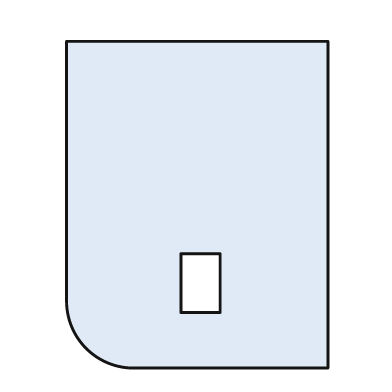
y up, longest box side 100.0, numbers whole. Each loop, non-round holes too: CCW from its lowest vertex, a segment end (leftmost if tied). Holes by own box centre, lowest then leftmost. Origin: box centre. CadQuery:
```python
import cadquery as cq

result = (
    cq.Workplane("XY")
    .moveTo(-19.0, -50.0)
    .lineTo(40.0, -50.0)
    .lineTo(40.0, 50.0)
    .lineTo(-40.0, 50.0)
    .lineTo(-40.0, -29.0)
    .threePointArc((-34.0, -44.0), (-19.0, -50.0))
    .close()
    .moveTo(-5.0, -33.0)
    .lineTo(7.0, -33.0)
    .lineTo(7.0, -15.0)
    .lineTo(-5.0, -15.0)
    .close()
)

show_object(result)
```